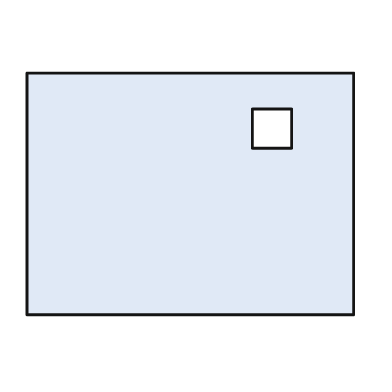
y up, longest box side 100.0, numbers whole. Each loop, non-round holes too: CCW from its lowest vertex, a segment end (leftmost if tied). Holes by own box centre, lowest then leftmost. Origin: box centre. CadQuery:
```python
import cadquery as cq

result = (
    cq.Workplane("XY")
    .moveTo(-50.0, -37.0)
    .lineTo(50.0, -37.0)
    .lineTo(50.0, 37.0)
    .lineTo(-50.0, 37.0)
    .close()
    .moveTo(19.0, 14.0)
    .lineTo(31.0, 14.0)
    .lineTo(31.0, 26.0)
    .lineTo(19.0, 26.0)
    .close()
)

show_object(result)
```